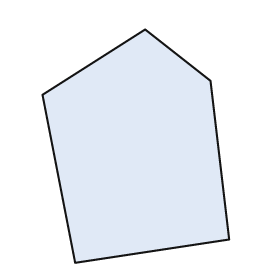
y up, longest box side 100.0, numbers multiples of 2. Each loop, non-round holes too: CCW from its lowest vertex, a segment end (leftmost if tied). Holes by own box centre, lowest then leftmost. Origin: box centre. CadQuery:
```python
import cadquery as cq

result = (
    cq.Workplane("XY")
    .moveTo(-26.0, -50.0)
    .lineTo(40.0, -40.0)
    .lineTo(32.0, 28.0)
    .lineTo(4.0, 50.0)
    .lineTo(-40.0, 22.0)
    .close()
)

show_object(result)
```